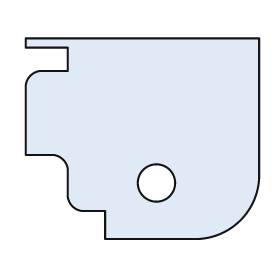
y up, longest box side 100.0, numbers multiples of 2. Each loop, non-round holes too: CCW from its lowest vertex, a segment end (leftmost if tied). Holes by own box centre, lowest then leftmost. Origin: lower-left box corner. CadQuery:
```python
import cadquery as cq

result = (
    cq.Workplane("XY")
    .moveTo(34.0, 0.0)
    .lineTo(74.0, 0.0)
    .threePointArc((92.0, 8.0), (100.0, 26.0))
    .lineTo(100.0, 86.0)
    .lineTo(0.0, 86.0)
    .lineTo(0.0, 82.0)
    .lineTo(18.0, 82.0)
    .lineTo(18.0, 72.0)
    .lineTo(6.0, 72.0)
    .threePointArc((2.0, 70.0), (0.0, 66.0))
    .lineTo(0.0, 36.0)
    .lineTo(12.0, 36.0)
    .threePointArc((16.0, 34.0), (18.0, 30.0))
    .lineTo(18.0, 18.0)
    .threePointArc((20.0, 14.0), (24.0, 12.0))
    .lineTo(34.0, 12.0)
    .close()
    .moveTo(56.0, 24.0)
    .circle(8.0)
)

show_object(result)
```